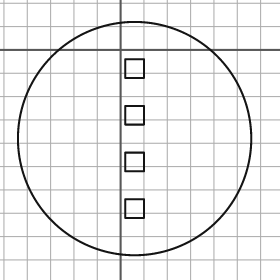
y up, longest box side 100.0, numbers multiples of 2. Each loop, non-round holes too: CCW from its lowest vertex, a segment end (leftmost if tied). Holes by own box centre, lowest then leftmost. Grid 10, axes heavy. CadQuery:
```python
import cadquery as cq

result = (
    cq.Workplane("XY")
    .moveTo(6.0, -38.0)
    .circle(50.0)
    .moveTo(2.0, -72.0)
    .lineTo(10.0, -72.0)
    .lineTo(10.0, -64.0)
    .lineTo(2.0, -64.0)
    .close()
    .moveTo(2.0, -52.0)
    .lineTo(10.0, -52.0)
    .lineTo(10.0, -44.0)
    .lineTo(2.0, -44.0)
    .close()
    .moveTo(2.0, -32.0)
    .lineTo(10.0, -32.0)
    .lineTo(10.0, -24.0)
    .lineTo(2.0, -24.0)
    .close()
    .moveTo(2.0, -12.0)
    .lineTo(10.0, -12.0)
    .lineTo(10.0, -4.0)
    .lineTo(2.0, -4.0)
    .close()
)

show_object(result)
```